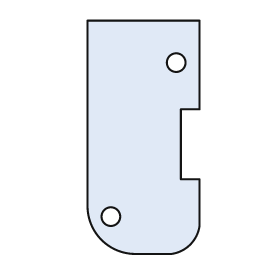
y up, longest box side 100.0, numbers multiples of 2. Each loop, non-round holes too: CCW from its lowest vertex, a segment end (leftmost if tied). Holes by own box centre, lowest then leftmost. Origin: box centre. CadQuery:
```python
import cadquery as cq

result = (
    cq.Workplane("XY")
    .moveTo(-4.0, -50.0)
    .lineTo(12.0, -50.0)
    .threePointArc((20.0, -46.0), (24.0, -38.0))
    .lineTo(24.0, -18.0)
    .lineTo(16.0, -18.0)
    .lineTo(16.0, 12.0)
    .lineTo(24.0, 12.0)
    .lineTo(24.0, 50.0)
    .lineTo(-24.0, 50.0)
    .lineTo(-24.0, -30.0)
    .threePointArc((-18.0, -44.0), (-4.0, -50.0))
    .close()
    .moveTo(-14.0, -34.0)
    .circle(4.0)
    .moveTo(14.0, 32.0)
    .circle(4.0)
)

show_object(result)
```